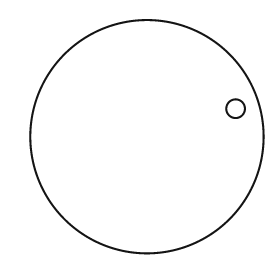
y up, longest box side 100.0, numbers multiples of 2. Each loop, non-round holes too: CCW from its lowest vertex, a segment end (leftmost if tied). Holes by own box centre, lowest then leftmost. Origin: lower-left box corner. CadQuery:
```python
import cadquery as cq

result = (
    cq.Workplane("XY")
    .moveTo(50.0, 50.0)
    .circle(50.0)
    .moveTo(88.0, 62.0)
    .circle(4.0)
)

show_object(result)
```